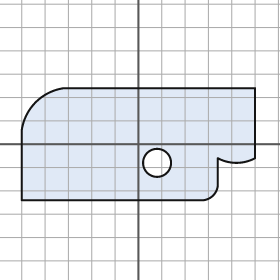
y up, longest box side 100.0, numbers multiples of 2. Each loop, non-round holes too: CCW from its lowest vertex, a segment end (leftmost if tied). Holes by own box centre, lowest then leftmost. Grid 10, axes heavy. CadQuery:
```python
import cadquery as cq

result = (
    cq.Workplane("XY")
    .moveTo(-50.0, -24.0)
    .lineTo(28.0, -24.0)
    .threePointArc((32.0, -22.0), (34.0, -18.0))
    .lineTo(34.0, -6.0)
    .threePointArc((42.0, -8.0), (50.0, -6.0))
    .lineTo(50.0, 24.0)
    .lineTo(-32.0, 24.0)
    .threePointArc((-44.0, 18.0), (-50.0, 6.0))
    .close()
    .moveTo(8.0, -8.0)
    .circle(6.0)
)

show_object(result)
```